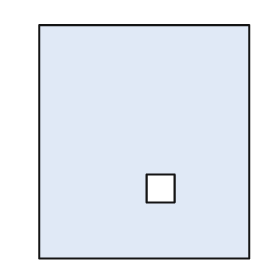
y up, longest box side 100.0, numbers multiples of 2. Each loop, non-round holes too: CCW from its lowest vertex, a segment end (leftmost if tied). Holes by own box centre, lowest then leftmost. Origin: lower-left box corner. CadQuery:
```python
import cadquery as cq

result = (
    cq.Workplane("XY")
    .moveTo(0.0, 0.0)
    .lineTo(90.0, 0.0)
    .lineTo(90.0, 100.0)
    .lineTo(0.0, 100.0)
    .close()
    .moveTo(46.0, 24.0)
    .lineTo(58.0, 24.0)
    .lineTo(58.0, 36.0)
    .lineTo(46.0, 36.0)
    .close()
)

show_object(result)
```